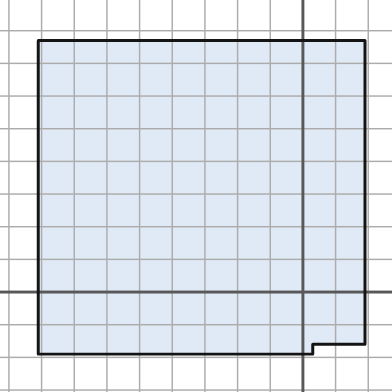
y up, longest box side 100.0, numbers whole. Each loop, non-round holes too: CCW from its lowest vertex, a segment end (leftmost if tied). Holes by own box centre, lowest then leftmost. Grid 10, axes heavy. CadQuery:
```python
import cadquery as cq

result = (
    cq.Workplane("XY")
    .moveTo(-81.0, -19.0)
    .lineTo(3.0, -19.0)
    .lineTo(3.0, -16.0)
    .lineTo(19.0, -16.0)
    .lineTo(19.0, 77.0)
    .lineTo(-81.0, 77.0)
    .close()
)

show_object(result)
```